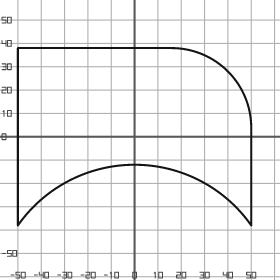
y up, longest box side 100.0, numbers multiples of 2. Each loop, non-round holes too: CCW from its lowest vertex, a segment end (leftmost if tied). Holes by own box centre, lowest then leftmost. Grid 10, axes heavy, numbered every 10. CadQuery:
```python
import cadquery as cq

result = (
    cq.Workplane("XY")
    .moveTo(-50.0, -38.0)
    .threePointArc((0.0, -12.0), (50.0, -38.0))
    .lineTo(50.0, 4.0)
    .threePointArc((40.0, 28.0), (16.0, 38.0))
    .lineTo(-50.0, 38.0)
    .close()
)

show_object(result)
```